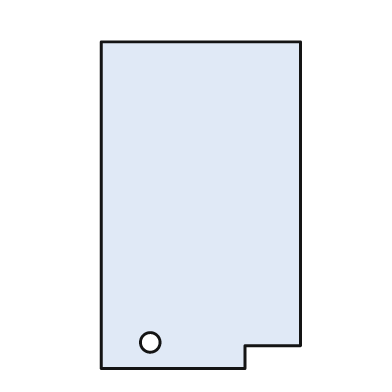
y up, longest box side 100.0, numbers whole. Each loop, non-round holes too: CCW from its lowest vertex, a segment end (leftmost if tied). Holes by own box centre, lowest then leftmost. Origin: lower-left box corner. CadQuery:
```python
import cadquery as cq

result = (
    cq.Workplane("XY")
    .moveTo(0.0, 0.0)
    .lineTo(44.0, 0.0)
    .lineTo(44.0, 7.0)
    .lineTo(61.0, 7.0)
    .lineTo(61.0, 100.0)
    .lineTo(0.0, 100.0)
    .close()
    .moveTo(15.0, 8.0)
    .circle(3.0)
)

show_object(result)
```